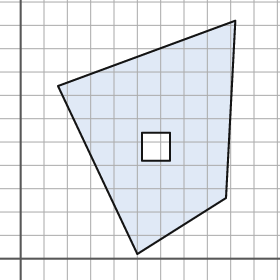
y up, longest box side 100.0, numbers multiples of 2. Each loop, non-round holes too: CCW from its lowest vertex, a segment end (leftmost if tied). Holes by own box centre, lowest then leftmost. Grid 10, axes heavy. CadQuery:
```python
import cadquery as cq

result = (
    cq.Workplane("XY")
    .moveTo(50.0, 2.0)
    .lineTo(88.0, 26.0)
    .lineTo(92.0, 102.0)
    .lineTo(16.0, 74.0)
    .close()
    .moveTo(52.0, 42.0)
    .lineTo(64.0, 42.0)
    .lineTo(64.0, 54.0)
    .lineTo(52.0, 54.0)
    .close()
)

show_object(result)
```